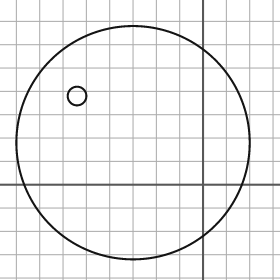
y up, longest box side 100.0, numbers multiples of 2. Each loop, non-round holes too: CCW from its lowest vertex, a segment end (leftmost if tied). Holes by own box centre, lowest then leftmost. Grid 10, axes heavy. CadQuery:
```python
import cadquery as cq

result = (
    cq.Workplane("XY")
    .moveTo(-30.0, 18.0)
    .circle(50.0)
    .moveTo(-54.0, 38.0)
    .circle(4.0)
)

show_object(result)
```